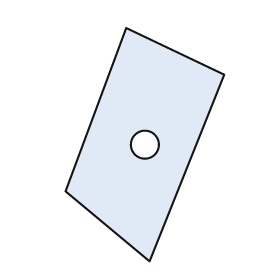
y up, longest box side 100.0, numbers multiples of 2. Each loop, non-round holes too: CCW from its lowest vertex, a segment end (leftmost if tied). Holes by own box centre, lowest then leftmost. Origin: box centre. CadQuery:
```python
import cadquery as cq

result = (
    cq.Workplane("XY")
    .moveTo(2.0, -50.0)
    .lineTo(34.0, 30.0)
    .lineTo(-8.0, 50.0)
    .lineTo(-34.0, -20.0)
    .close()
    .moveTo(0.0, 0.0)
    .circle(6.0)
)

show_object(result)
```